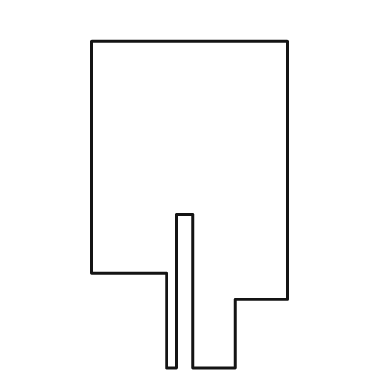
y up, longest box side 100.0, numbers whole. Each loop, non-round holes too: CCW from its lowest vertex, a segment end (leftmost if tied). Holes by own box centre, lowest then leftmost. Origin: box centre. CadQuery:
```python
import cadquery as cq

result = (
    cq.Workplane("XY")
    .moveTo(-7.0, -50.0)
    .lineTo(-4.0, -50.0)
    .lineTo(-4.0, -3.0)
    .lineTo(1.0, -3.0)
    .lineTo(1.0, -50.0)
    .lineTo(14.0, -50.0)
    .lineTo(14.0, -29.0)
    .lineTo(30.0, -29.0)
    .lineTo(30.0, 50.0)
    .lineTo(-30.0, 50.0)
    .lineTo(-30.0, -21.0)
    .lineTo(-7.0, -21.0)
    .close()
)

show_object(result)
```